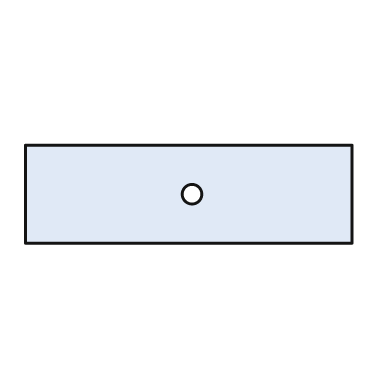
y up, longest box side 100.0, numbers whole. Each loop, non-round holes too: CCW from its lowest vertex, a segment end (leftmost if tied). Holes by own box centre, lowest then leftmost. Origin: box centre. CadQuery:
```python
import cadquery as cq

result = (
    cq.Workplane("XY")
    .moveTo(-50.0, -15.0)
    .lineTo(50.0, -15.0)
    .lineTo(50.0, 15.0)
    .lineTo(-50.0, 15.0)
    .close()
    .moveTo(1.0, 0.0)
    .circle(3.0)
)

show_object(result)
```